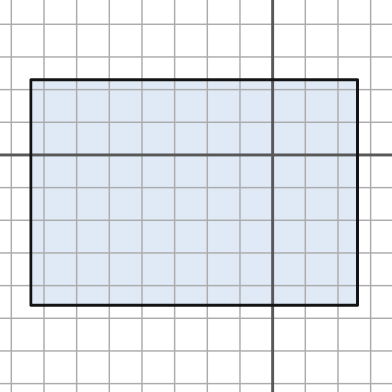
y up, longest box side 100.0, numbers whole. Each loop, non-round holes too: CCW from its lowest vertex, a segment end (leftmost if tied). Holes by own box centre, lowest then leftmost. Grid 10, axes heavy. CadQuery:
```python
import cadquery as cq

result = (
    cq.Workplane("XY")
    .moveTo(-74.0, -46.0)
    .lineTo(26.0, -46.0)
    .lineTo(26.0, 23.0)
    .lineTo(-74.0, 23.0)
    .close()
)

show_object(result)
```